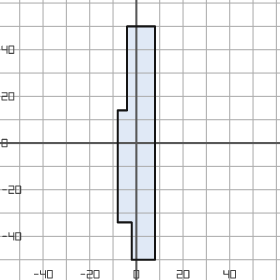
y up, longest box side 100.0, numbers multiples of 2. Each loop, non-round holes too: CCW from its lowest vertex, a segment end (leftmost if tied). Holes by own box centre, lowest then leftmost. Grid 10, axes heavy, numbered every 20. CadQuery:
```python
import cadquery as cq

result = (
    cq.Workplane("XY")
    .moveTo(-2.0, -50.0)
    .lineTo(8.0, -50.0)
    .lineTo(8.0, 50.0)
    .lineTo(-4.0, 50.0)
    .lineTo(-4.0, 14.0)
    .lineTo(-8.0, 14.0)
    .lineTo(-8.0, -34.0)
    .lineTo(-2.0, -34.0)
    .close()
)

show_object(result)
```